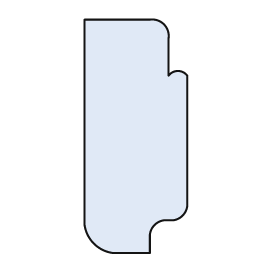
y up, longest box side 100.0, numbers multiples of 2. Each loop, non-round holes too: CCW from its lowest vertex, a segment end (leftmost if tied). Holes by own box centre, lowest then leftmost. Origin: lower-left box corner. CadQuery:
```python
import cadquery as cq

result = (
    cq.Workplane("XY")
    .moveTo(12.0, 0.0)
    .lineTo(28.0, 0.0)
    .lineTo(28.0, 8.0)
    .threePointArc((30.0, 12.0), (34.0, 14.0))
    .lineTo(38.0, 14.0)
    .threePointArc((42.0, 16.0), (44.0, 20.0))
    .lineTo(44.0, 76.0)
    .threePointArc((40.0, 78.0), (36.0, 76.0))
    .lineTo(36.0, 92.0)
    .threePointArc((34.0, 98.0), (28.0, 100.0))
    .lineTo(0.0, 100.0)
    .lineTo(0.0, 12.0)
    .threePointArc((4.0, 4.0), (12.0, 0.0))
    .close()
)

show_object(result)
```